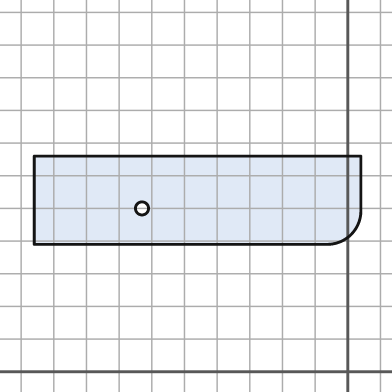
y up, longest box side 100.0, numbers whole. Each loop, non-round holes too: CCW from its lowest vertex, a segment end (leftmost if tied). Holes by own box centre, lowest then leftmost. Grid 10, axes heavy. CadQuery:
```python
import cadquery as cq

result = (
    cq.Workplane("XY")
    .moveTo(-96.0, 39.0)
    .lineTo(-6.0, 39.0)
    .threePointArc((1.0, 42.0), (4.0, 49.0))
    .lineTo(4.0, 66.0)
    .lineTo(-96.0, 66.0)
    .close()
    .moveTo(-63.0, 50.0)
    .circle(2.0)
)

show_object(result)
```